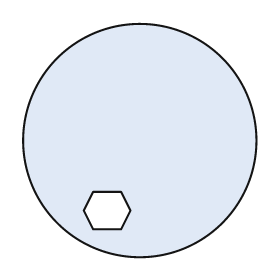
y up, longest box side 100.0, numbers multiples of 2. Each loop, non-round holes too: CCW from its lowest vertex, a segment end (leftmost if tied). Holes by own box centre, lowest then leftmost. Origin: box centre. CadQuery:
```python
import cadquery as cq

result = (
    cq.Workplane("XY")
    .moveTo(0.0, 0.0)
    .circle(50.0)
    .moveTo(-20.0, -38.0)
    .lineTo(-8.0, -38.0)
    .lineTo(-4.0, -30.0)
    .lineTo(-8.0, -22.0)
    .lineTo(-20.0, -22.0)
    .lineTo(-24.0, -30.0)
    .close()
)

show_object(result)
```